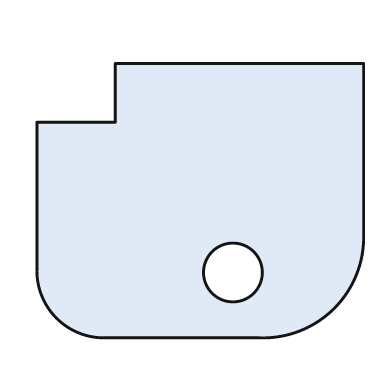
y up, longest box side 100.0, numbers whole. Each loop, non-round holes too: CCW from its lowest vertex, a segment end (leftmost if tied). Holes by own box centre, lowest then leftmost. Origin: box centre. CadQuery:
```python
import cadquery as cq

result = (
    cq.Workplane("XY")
    .moveTo(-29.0, -42.0)
    .lineTo(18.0, -42.0)
    .threePointArc((41.0, -33.0), (50.0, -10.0))
    .lineTo(50.0, 42.0)
    .lineTo(-26.0, 42.0)
    .lineTo(-26.0, 24.0)
    .lineTo(-50.0, 24.0)
    .lineTo(-50.0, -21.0)
    .threePointArc((-44.0, -36.0), (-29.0, -42.0))
    .close()
    .moveTo(10.0, -22.0)
    .circle(9.0)
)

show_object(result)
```